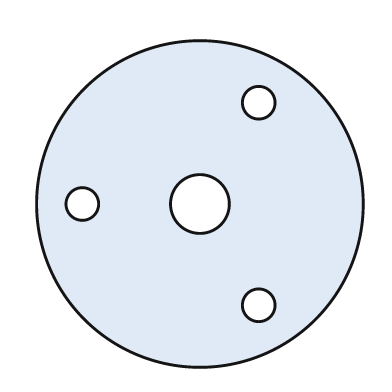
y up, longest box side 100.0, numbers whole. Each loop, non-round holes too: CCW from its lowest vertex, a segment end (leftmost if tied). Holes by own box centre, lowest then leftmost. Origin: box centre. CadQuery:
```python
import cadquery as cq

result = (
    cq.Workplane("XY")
    .moveTo(0.0, 0.0)
    .circle(50.0)
    .moveTo(18.0, -31.0)
    .circle(5.0)
    .moveTo(-36.0, 0.0)
    .circle(5.0)
    .moveTo(0.0, 0.0)
    .circle(9.0)
    .moveTo(18.0, 31.0)
    .circle(5.0)
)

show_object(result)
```